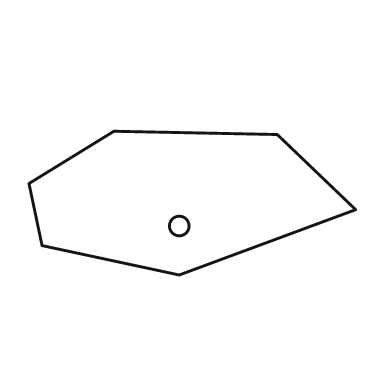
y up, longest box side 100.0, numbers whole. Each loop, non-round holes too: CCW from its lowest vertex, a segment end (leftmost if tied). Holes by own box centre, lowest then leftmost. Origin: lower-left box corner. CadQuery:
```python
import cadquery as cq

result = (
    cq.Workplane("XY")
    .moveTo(46.0, 0.0)
    .lineTo(100.0, 20.0)
    .lineTo(76.0, 43.0)
    .lineTo(26.0, 44.0)
    .lineTo(0.0, 28.0)
    .lineTo(4.0, 9.0)
    .close()
    .moveTo(46.0, 15.0)
    .circle(3.0)
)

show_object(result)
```